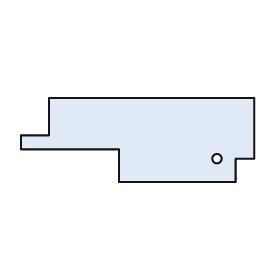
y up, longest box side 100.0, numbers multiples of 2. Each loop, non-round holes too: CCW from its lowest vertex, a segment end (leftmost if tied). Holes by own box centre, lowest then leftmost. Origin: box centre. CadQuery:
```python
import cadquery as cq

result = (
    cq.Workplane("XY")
    .moveTo(-8.0, -18.0)
    .lineTo(42.0, -18.0)
    .lineTo(42.0, -8.0)
    .lineTo(50.0, -8.0)
    .lineTo(50.0, 18.0)
    .lineTo(-38.0, 18.0)
    .lineTo(-38.0, 2.0)
    .lineTo(-50.0, 2.0)
    .lineTo(-50.0, -4.0)
    .lineTo(-8.0, -4.0)
    .close()
    .moveTo(34.0, -8.0)
    .circle(2.0)
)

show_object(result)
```